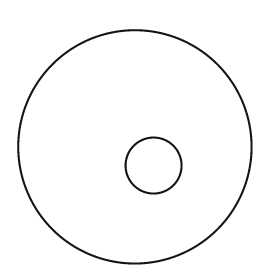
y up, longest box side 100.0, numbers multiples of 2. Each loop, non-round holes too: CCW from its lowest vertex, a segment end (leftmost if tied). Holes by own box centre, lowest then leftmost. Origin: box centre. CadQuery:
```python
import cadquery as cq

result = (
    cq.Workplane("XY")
    .moveTo(0.0, 0.0)
    .circle(50.0)
    .moveTo(8.0, -8.0)
    .circle(12.0)
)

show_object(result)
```